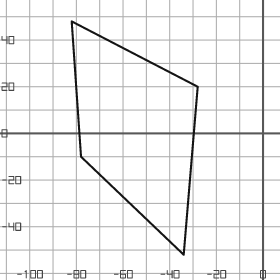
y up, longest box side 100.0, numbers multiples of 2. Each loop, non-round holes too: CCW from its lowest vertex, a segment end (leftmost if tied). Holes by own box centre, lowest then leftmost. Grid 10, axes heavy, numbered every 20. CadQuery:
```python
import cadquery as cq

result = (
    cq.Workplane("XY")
    .moveTo(-34.0, -52.0)
    .lineTo(-28.0, 20.0)
    .lineTo(-82.0, 48.0)
    .lineTo(-78.0, -10.0)
    .close()
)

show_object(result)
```